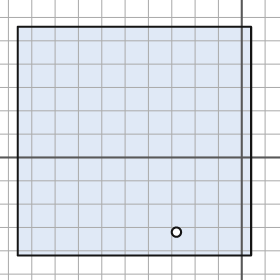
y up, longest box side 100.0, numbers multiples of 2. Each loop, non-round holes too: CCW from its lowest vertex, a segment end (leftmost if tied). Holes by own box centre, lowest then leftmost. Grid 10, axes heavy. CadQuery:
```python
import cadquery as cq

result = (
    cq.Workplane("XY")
    .moveTo(-96.0, -42.0)
    .lineTo(4.0, -42.0)
    .lineTo(4.0, 56.0)
    .lineTo(-96.0, 56.0)
    .close()
    .moveTo(-28.0, -32.0)
    .circle(2.0)
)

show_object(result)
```